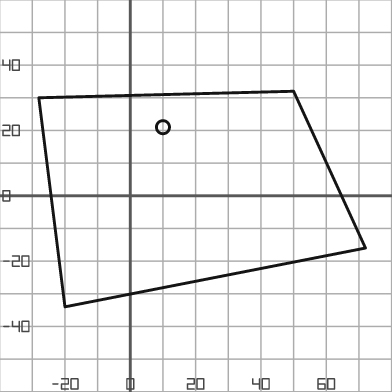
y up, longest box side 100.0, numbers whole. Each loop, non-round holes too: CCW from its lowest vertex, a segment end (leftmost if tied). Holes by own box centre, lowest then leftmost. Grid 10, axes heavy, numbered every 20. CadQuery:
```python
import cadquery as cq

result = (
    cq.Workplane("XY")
    .moveTo(-20.0, -34.0)
    .lineTo(72.0, -16.0)
    .lineTo(50.0, 32.0)
    .lineTo(-28.0, 30.0)
    .close()
    .moveTo(10.0, 21.0)
    .circle(2.0)
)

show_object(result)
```